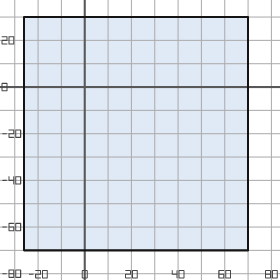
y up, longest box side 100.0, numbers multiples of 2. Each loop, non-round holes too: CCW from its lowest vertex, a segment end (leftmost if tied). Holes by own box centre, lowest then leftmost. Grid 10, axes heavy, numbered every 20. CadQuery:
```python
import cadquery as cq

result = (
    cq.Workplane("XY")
    .moveTo(-26.0, -70.0)
    .lineTo(70.0, -70.0)
    .lineTo(70.0, 30.0)
    .lineTo(-26.0, 30.0)
    .close()
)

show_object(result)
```